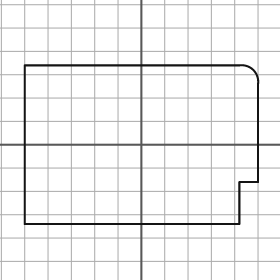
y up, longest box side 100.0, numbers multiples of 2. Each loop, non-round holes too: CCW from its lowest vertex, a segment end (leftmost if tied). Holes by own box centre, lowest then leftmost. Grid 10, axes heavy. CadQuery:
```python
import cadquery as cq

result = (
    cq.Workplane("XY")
    .moveTo(-50.0, -34.0)
    .lineTo(42.0, -34.0)
    .lineTo(42.0, -16.0)
    .lineTo(50.0, -16.0)
    .lineTo(50.0, 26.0)
    .threePointArc((48.0, 32.0), (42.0, 34.0))
    .lineTo(-50.0, 34.0)
    .close()
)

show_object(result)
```